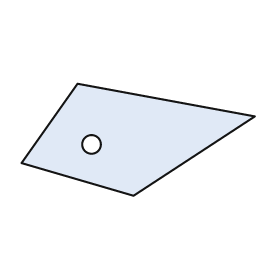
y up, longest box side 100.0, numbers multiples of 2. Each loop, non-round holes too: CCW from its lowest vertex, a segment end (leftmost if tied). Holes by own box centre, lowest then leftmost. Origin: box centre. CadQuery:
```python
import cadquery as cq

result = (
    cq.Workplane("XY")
    .moveTo(-2.0, -24.0)
    .lineTo(50.0, 10.0)
    .lineTo(-26.0, 24.0)
    .lineTo(-50.0, -10.0)
    .close()
    .moveTo(-20.0, -2.0)
    .circle(4.0)
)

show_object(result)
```